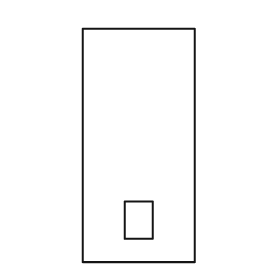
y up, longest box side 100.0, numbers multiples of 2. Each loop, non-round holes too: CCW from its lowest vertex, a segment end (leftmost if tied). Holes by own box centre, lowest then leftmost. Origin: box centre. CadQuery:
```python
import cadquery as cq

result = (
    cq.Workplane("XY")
    .moveTo(-24.0, -50.0)
    .lineTo(24.0, -50.0)
    .lineTo(24.0, 50.0)
    .lineTo(-24.0, 50.0)
    .close()
    .moveTo(-6.0, -40.0)
    .lineTo(6.0, -40.0)
    .lineTo(6.0, -24.0)
    .lineTo(-6.0, -24.0)
    .close()
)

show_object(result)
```